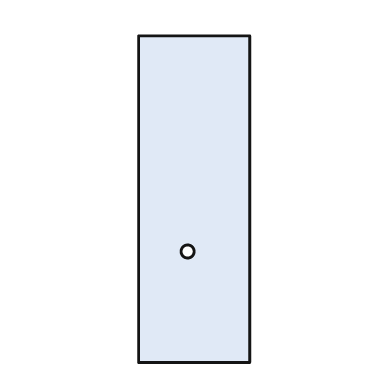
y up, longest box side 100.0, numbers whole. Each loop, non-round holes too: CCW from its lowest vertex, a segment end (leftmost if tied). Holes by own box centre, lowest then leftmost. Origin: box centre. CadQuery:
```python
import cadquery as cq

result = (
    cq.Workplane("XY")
    .moveTo(-17.0, -50.0)
    .lineTo(17.0, -50.0)
    .lineTo(17.0, 50.0)
    .lineTo(-17.0, 50.0)
    .close()
    .moveTo(-2.0, -16.0)
    .circle(2.0)
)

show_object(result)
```